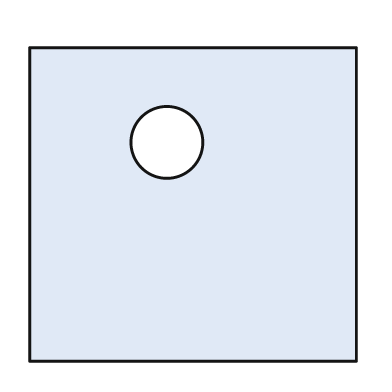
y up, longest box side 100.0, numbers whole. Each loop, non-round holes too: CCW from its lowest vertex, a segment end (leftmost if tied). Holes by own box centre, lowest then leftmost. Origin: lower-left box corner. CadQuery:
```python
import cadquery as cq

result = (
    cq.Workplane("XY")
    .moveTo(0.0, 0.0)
    .lineTo(100.0, 0.0)
    .lineTo(100.0, 96.0)
    .lineTo(0.0, 96.0)
    .close()
    .moveTo(42.0, 67.0)
    .circle(11.0)
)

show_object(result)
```